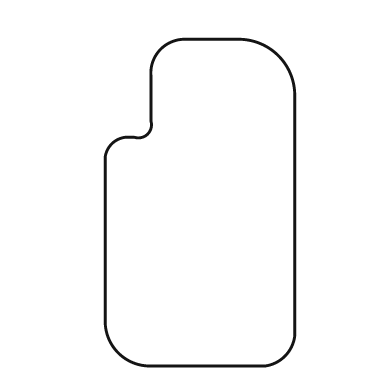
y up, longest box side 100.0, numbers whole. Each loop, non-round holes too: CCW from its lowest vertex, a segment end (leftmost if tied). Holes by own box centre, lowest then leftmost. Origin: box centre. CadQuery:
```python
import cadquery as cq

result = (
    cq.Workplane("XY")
    .moveTo(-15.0, -50.0)
    .lineTo(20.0, -50.0)
    .threePointArc((26.0, -47.0), (29.0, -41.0))
    .lineTo(29.0, 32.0)
    .threePointArc((24.0, 45.0), (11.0, 50.0))
    .lineTo(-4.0, 50.0)
    .threePointArc((-12.0, 47.0), (-15.0, 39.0))
    .lineTo(-15.0, 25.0)
    .threePointArc((-16.0, 21.0), (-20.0, 20.0))
    .lineTo(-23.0, 20.0)
    .threePointArc((-27.0, 18.0), (-29.0, 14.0))
    .lineTo(-29.0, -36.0)
    .threePointArc((-25.0, -46.0), (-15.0, -50.0))
    .close()
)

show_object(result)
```